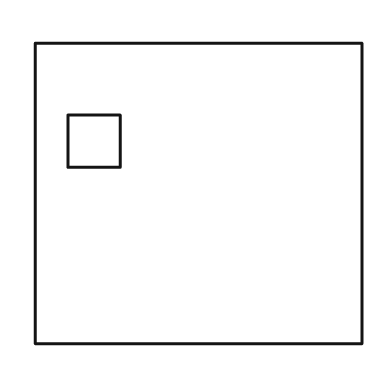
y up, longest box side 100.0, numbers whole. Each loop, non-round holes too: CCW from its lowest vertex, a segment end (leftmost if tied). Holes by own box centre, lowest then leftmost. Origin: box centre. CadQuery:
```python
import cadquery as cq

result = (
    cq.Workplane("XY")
    .moveTo(-50.0, -46.0)
    .lineTo(50.0, -46.0)
    .lineTo(50.0, 46.0)
    .lineTo(-50.0, 46.0)
    .close()
    .moveTo(-40.0, 8.0)
    .lineTo(-24.0, 8.0)
    .lineTo(-24.0, 24.0)
    .lineTo(-40.0, 24.0)
    .close()
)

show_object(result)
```